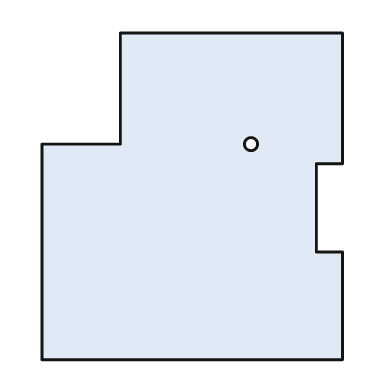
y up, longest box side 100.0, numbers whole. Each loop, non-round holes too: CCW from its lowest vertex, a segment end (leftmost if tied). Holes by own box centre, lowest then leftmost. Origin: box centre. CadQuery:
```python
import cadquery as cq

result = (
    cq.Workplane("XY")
    .moveTo(-46.0, -50.0)
    .lineTo(46.0, -50.0)
    .lineTo(46.0, -17.0)
    .lineTo(38.0, -17.0)
    .lineTo(38.0, 10.0)
    .lineTo(46.0, 10.0)
    .lineTo(46.0, 50.0)
    .lineTo(-22.0, 50.0)
    .lineTo(-22.0, 16.0)
    .lineTo(-46.0, 16.0)
    .close()
    .moveTo(18.0, 16.0)
    .circle(2.0)
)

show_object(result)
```